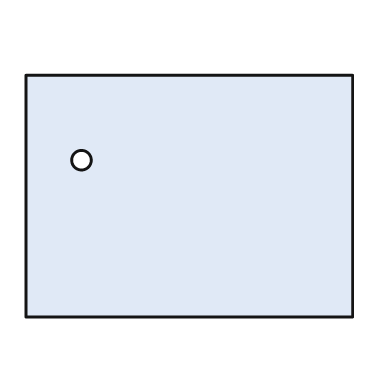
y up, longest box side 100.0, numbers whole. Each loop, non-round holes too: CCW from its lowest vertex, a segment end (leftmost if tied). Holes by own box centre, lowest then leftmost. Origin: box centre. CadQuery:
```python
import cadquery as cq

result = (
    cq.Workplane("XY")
    .moveTo(-50.0, -37.0)
    .lineTo(50.0, -37.0)
    .lineTo(50.0, 37.0)
    .lineTo(-50.0, 37.0)
    .close()
    .moveTo(-33.0, 11.0)
    .circle(3.0)
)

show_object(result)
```